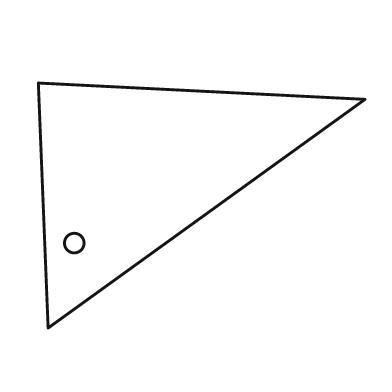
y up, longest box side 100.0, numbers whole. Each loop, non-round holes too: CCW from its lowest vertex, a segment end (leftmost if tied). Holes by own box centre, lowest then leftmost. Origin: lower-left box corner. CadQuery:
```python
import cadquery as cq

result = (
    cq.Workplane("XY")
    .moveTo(3.0, 0.0)
    .lineTo(100.0, 70.0)
    .lineTo(0.0, 75.0)
    .close()
    .moveTo(11.0, 26.0)
    .circle(3.0)
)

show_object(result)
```